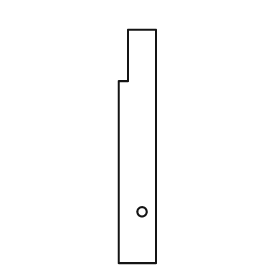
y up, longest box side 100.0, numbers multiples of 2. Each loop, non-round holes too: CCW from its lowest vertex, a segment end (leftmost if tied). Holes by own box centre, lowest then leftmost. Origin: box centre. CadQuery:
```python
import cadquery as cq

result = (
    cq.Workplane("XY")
    .moveTo(-8.0, -50.0)
    .lineTo(8.0, -50.0)
    .lineTo(8.0, 50.0)
    .lineTo(-4.0, 50.0)
    .lineTo(-4.0, 28.0)
    .lineTo(-8.0, 28.0)
    .close()
    .moveTo(2.0, -28.0)
    .circle(2.0)
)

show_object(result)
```